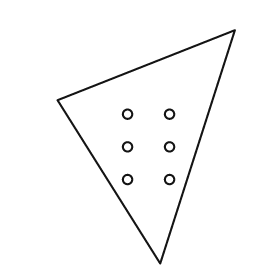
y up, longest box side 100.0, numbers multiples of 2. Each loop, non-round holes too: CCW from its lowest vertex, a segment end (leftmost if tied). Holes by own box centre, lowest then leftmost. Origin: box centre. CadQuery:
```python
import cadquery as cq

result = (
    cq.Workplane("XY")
    .moveTo(6.0, -50.0)
    .lineTo(38.0, 50.0)
    .lineTo(-38.0, 20.0)
    .close()
    .moveTo(-8.0, -14.0)
    .circle(2.0)
    .moveTo(10.0, -14.0)
    .circle(2.0)
    .moveTo(-8.0, 0.0)
    .circle(2.0)
    .moveTo(10.0, 0.0)
    .circle(2.0)
    .moveTo(-8.0, 14.0)
    .circle(2.0)
    .moveTo(10.0, 14.0)
    .circle(2.0)
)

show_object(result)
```